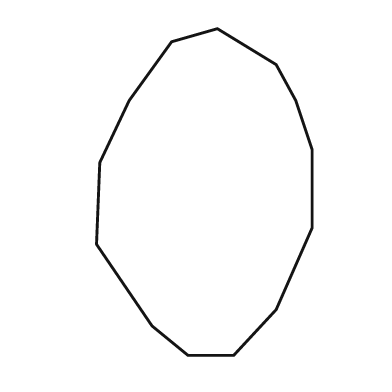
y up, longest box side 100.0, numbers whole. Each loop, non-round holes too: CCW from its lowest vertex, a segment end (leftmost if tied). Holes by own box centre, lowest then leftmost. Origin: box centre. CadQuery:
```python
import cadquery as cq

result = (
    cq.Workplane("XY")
    .moveTo(-5.0, -50.0)
    .lineTo(9.0, -50.0)
    .lineTo(22.0, -36.0)
    .lineTo(33.0, -11.0)
    .lineTo(33.0, 13.0)
    .lineTo(28.0, 28.0)
    .lineTo(22.0, 39.0)
    .lineTo(4.0, 50.0)
    .lineTo(-10.0, 46.0)
    .lineTo(-23.0, 28.0)
    .lineTo(-32.0, 9.0)
    .lineTo(-33.0, -16.0)
    .lineTo(-16.0, -41.0)
    .close()
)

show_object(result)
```